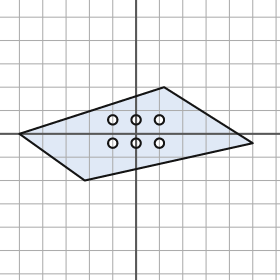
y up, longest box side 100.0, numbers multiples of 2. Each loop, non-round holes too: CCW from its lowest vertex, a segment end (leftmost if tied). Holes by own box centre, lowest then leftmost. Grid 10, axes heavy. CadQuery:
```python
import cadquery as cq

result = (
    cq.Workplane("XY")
    .moveTo(-22.0, -20.0)
    .lineTo(50.0, -4.0)
    .lineTo(12.0, 20.0)
    .lineTo(-50.0, 0.0)
    .close()
    .moveTo(-10.0, -4.0)
    .circle(2.0)
    .moveTo(0.0, -4.0)
    .circle(2.0)
    .moveTo(10.0, -4.0)
    .circle(2.0)
    .moveTo(-10.0, 6.0)
    .circle(2.0)
    .moveTo(0.0, 6.0)
    .circle(2.0)
    .moveTo(10.0, 6.0)
    .circle(2.0)
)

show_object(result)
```